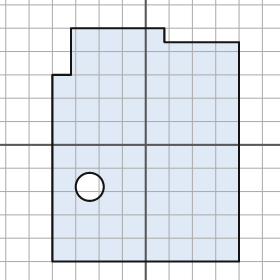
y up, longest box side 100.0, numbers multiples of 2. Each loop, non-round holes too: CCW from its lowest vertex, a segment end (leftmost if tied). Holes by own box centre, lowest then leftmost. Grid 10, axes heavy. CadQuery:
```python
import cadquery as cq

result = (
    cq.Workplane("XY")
    .moveTo(-40.0, -50.0)
    .lineTo(40.0, -50.0)
    .lineTo(40.0, 44.0)
    .lineTo(8.0, 44.0)
    .lineTo(8.0, 50.0)
    .lineTo(-32.0, 50.0)
    .lineTo(-32.0, 30.0)
    .lineTo(-40.0, 30.0)
    .close()
    .moveTo(-24.0, -18.0)
    .circle(6.0)
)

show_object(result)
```